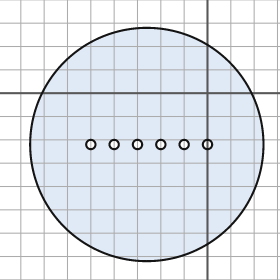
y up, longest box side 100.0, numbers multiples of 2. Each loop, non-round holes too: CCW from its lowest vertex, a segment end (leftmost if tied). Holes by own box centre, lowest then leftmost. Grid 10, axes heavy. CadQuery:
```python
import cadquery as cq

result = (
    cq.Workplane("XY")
    .moveTo(-26.0, -22.0)
    .circle(50.0)
    .moveTo(-50.0, -22.0)
    .circle(2.0)
    .moveTo(-40.0, -22.0)
    .circle(2.0)
    .moveTo(-30.0, -22.0)
    .circle(2.0)
    .moveTo(-20.0, -22.0)
    .circle(2.0)
    .moveTo(-10.0, -22.0)
    .circle(2.0)
    .moveTo(0.0, -22.0)
    .circle(2.0)
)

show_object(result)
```